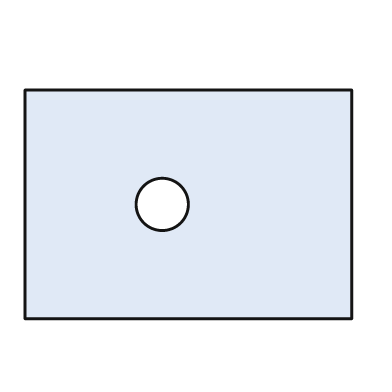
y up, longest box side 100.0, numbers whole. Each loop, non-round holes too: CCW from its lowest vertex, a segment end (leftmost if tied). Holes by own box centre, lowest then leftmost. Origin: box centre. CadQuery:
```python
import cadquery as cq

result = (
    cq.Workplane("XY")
    .moveTo(-50.0, -35.0)
    .lineTo(50.0, -35.0)
    .lineTo(50.0, 35.0)
    .lineTo(-50.0, 35.0)
    .close()
    .moveTo(-8.0, 0.0)
    .circle(8.0)
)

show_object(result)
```